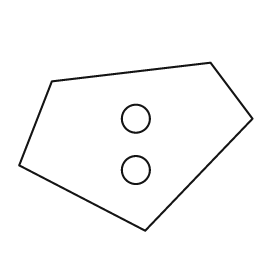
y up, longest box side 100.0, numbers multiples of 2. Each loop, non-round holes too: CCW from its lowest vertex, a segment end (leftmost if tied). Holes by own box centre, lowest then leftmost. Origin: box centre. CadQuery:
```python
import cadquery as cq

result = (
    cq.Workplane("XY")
    .moveTo(4.0, -36.0)
    .lineTo(50.0, 12.0)
    .lineTo(32.0, 36.0)
    .lineTo(-36.0, 28.0)
    .lineTo(-50.0, -8.0)
    .close()
    .moveTo(0.0, -10.0)
    .circle(6.0)
    .moveTo(0.0, 12.0)
    .circle(6.0)
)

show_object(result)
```